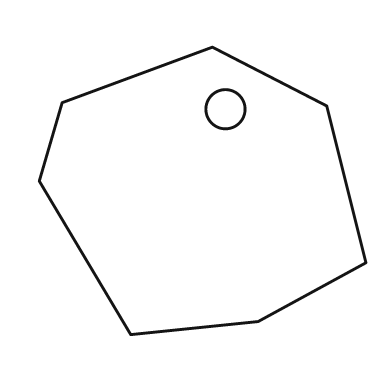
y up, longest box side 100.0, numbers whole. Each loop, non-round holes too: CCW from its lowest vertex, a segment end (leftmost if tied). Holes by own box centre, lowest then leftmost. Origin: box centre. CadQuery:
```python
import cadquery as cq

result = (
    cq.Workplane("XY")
    .moveTo(-22.0, -44.0)
    .lineTo(17.0, -40.0)
    .lineTo(50.0, -22.0)
    .lineTo(38.0, 26.0)
    .lineTo(3.0, 44.0)
    .lineTo(-43.0, 27.0)
    .lineTo(-50.0, 3.0)
    .close()
    .moveTo(7.0, 25.0)
    .circle(6.0)
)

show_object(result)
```